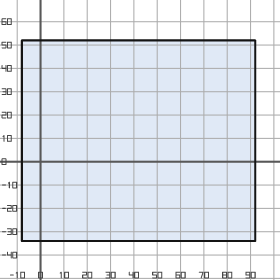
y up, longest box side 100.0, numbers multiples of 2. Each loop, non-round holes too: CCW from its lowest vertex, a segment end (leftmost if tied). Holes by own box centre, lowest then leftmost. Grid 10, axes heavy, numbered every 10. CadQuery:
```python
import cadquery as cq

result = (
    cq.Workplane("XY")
    .moveTo(-8.0, -34.0)
    .lineTo(92.0, -34.0)
    .lineTo(92.0, 52.0)
    .lineTo(-8.0, 52.0)
    .close()
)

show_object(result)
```